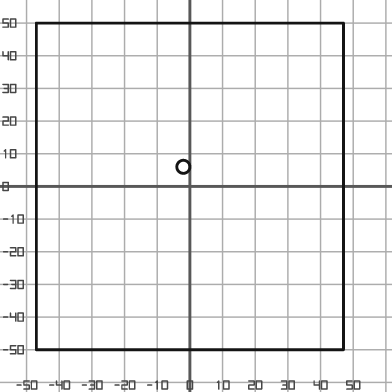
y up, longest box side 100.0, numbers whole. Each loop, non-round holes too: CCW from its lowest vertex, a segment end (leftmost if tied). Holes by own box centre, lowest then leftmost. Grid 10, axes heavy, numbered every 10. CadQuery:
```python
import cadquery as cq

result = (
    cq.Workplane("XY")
    .moveTo(-47.0, -50.0)
    .lineTo(47.0, -50.0)
    .lineTo(47.0, 50.0)
    .lineTo(-47.0, 50.0)
    .close()
    .moveTo(-2.0, 6.0)
    .circle(2.0)
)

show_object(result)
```